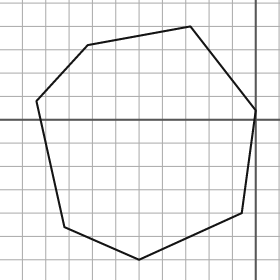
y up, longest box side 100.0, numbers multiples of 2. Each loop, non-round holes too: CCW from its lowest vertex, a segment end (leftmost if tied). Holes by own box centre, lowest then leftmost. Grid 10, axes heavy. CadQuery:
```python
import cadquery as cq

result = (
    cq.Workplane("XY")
    .moveTo(-50.0, -60.0)
    .lineTo(-6.0, -40.0)
    .lineTo(0.0, 4.0)
    .lineTo(-28.0, 40.0)
    .lineTo(-72.0, 32.0)
    .lineTo(-94.0, 8.0)
    .lineTo(-82.0, -46.0)
    .close()
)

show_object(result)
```